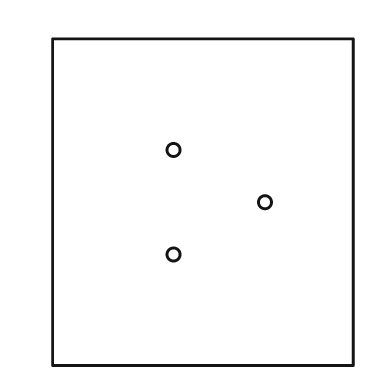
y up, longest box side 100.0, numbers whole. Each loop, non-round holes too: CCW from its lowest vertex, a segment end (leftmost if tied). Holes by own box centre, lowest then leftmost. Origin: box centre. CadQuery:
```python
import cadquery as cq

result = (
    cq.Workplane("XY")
    .moveTo(-46.0, -50.0)
    .lineTo(46.0, -50.0)
    .lineTo(46.0, 50.0)
    .lineTo(-46.0, 50.0)
    .close()
    .moveTo(-9.0, -16.0)
    .circle(2.0)
    .moveTo(19.0, 0.0)
    .circle(2.0)
    .moveTo(-9.0, 16.0)
    .circle(2.0)
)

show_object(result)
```